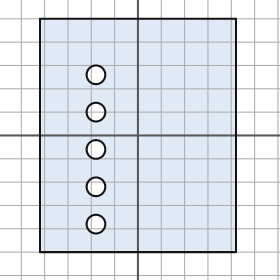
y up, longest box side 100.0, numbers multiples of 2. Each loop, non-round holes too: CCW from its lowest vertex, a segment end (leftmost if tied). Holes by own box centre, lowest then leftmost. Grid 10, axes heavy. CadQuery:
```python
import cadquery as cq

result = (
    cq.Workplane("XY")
    .moveTo(-42.0, -50.0)
    .lineTo(42.0, -50.0)
    .lineTo(42.0, 50.0)
    .lineTo(-42.0, 50.0)
    .close()
    .moveTo(-18.0, -38.0)
    .circle(4.0)
    .moveTo(-18.0, -22.0)
    .circle(4.0)
    .moveTo(-18.0, -6.0)
    .circle(4.0)
    .moveTo(-18.0, 10.0)
    .circle(4.0)
    .moveTo(-18.0, 26.0)
    .circle(4.0)
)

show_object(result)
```